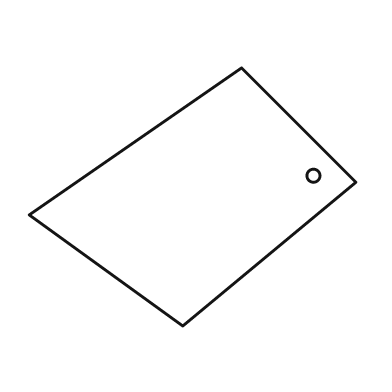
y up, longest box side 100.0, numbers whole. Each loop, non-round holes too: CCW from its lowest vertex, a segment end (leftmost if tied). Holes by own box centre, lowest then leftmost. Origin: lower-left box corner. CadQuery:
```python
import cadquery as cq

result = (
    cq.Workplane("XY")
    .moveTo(47.0, 0.0)
    .lineTo(100.0, 44.0)
    .lineTo(65.0, 79.0)
    .lineTo(0.0, 34.0)
    .close()
    .moveTo(87.0, 46.0)
    .circle(2.0)
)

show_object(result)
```